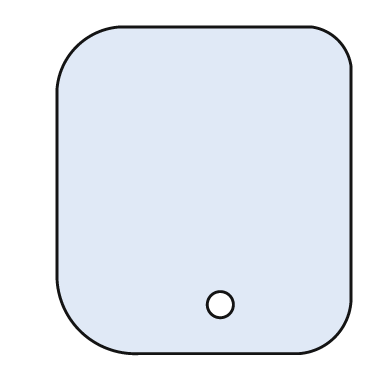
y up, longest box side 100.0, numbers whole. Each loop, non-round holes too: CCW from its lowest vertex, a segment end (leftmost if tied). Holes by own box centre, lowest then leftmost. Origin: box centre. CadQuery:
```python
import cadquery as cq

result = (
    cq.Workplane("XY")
    .moveTo(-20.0, -50.0)
    .lineTo(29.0, -50.0)
    .threePointArc((40.0, -45.0), (45.0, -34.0))
    .lineTo(45.0, 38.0)
    .threePointArc((41.0, 46.0), (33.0, 50.0))
    .lineTo(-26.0, 50.0)
    .threePointArc((-39.0, 44.0), (-45.0, 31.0))
    .lineTo(-45.0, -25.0)
    .threePointArc((-38.0, -43.0), (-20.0, -50.0))
    .close()
    .moveTo(5.0, -35.0)
    .circle(4.0)
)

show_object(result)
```